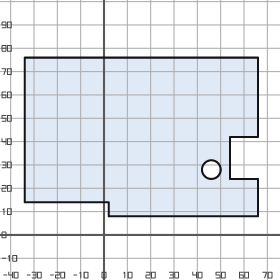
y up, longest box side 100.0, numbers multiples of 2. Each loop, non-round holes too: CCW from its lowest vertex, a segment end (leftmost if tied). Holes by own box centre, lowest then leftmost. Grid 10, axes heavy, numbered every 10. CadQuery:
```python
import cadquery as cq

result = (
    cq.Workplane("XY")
    .moveTo(2.0, 8.0)
    .lineTo(66.0, 8.0)
    .lineTo(66.0, 24.0)
    .lineTo(54.0, 24.0)
    .lineTo(54.0, 42.0)
    .lineTo(66.0, 42.0)
    .lineTo(66.0, 76.0)
    .lineTo(-34.0, 76.0)
    .lineTo(-34.0, 14.0)
    .lineTo(2.0, 14.0)
    .close()
    .moveTo(46.0, 28.0)
    .circle(4.0)
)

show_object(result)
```